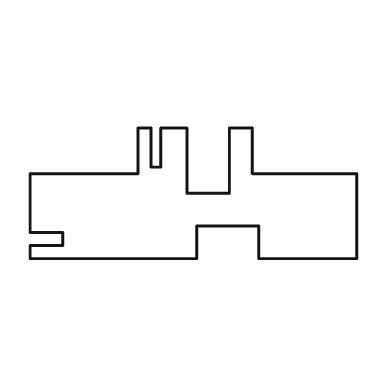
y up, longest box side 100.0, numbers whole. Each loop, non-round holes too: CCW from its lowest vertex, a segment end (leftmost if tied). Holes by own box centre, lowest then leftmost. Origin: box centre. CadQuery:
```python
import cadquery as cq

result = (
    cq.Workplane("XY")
    .moveTo(-50.0, -20.0)
    .lineTo(1.0, -20.0)
    .lineTo(1.0, -10.0)
    .lineTo(20.0, -10.0)
    .lineTo(20.0, -20.0)
    .lineTo(50.0, -20.0)
    .lineTo(50.0, 6.0)
    .lineTo(18.0, 6.0)
    .lineTo(18.0, 20.0)
    .lineTo(11.0, 20.0)
    .lineTo(11.0, 0.0)
    .lineTo(-2.0, 0.0)
    .lineTo(-2.0, 20.0)
    .lineTo(-10.0, 20.0)
    .lineTo(-10.0, 8.0)
    .lineTo(-13.0, 8.0)
    .lineTo(-13.0, 20.0)
    .lineTo(-17.0, 20.0)
    .lineTo(-17.0, 6.0)
    .lineTo(-50.0, 6.0)
    .lineTo(-50.0, -12.0)
    .lineTo(-40.0, -12.0)
    .lineTo(-40.0, -16.0)
    .lineTo(-50.0, -16.0)
    .close()
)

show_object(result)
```